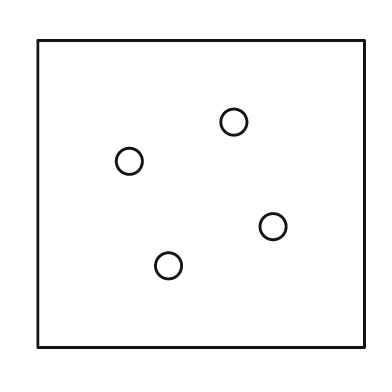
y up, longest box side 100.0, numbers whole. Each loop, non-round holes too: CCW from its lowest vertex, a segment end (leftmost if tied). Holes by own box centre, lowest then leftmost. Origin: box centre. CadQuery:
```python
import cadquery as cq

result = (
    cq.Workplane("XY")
    .moveTo(-50.0, -47.0)
    .lineTo(50.0, -47.0)
    .lineTo(50.0, 47.0)
    .lineTo(-50.0, 47.0)
    .close()
    .moveTo(-10.0, -22.0)
    .circle(4.0)
    .moveTo(22.0, -10.0)
    .circle(4.0)
    .moveTo(-22.0, 10.0)
    .circle(4.0)
    .moveTo(10.0, 22.0)
    .circle(4.0)
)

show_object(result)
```